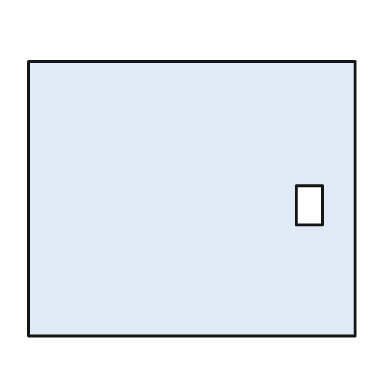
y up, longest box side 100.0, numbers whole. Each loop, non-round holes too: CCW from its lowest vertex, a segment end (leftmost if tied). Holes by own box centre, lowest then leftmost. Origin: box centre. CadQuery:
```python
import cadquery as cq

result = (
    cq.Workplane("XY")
    .moveTo(-50.0, -42.0)
    .lineTo(50.0, -42.0)
    .lineTo(50.0, 42.0)
    .lineTo(-50.0, 42.0)
    .close()
    .moveTo(32.0, -8.0)
    .lineTo(40.0, -8.0)
    .lineTo(40.0, 4.0)
    .lineTo(32.0, 4.0)
    .close()
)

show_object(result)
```